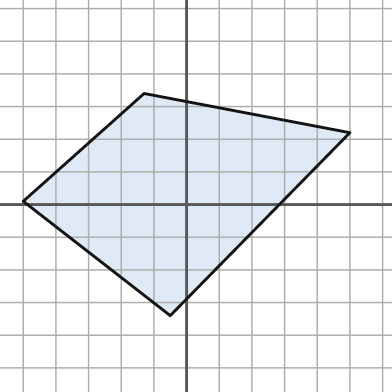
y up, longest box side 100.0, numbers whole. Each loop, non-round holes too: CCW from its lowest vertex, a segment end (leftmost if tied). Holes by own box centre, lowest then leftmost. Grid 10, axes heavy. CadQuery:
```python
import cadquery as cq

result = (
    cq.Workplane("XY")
    .moveTo(-5.0, -34.0)
    .lineTo(50.0, 22.0)
    .lineTo(-13.0, 34.0)
    .lineTo(-50.0, 1.0)
    .close()
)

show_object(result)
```